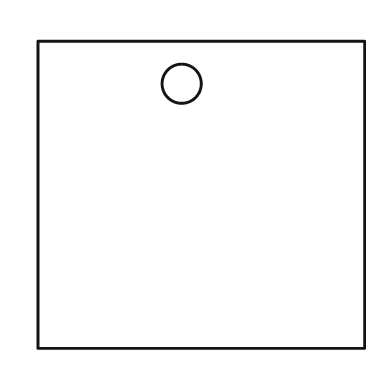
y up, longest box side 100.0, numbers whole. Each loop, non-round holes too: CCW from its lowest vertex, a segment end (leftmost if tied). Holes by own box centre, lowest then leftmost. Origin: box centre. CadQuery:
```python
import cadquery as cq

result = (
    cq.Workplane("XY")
    .moveTo(-50.0, -47.0)
    .lineTo(50.0, -47.0)
    .lineTo(50.0, 47.0)
    .lineTo(-50.0, 47.0)
    .close()
    .moveTo(-6.0, 34.0)
    .circle(6.0)
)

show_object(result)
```